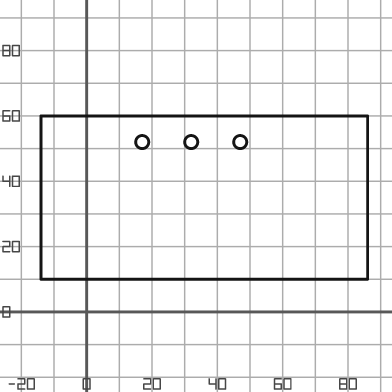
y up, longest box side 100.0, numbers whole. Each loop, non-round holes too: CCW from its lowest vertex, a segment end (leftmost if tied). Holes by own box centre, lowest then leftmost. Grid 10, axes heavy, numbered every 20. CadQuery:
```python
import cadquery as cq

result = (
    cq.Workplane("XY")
    .moveTo(-14.0, 10.0)
    .lineTo(86.0, 10.0)
    .lineTo(86.0, 60.0)
    .lineTo(-14.0, 60.0)
    .close()
    .moveTo(17.0, 52.0)
    .circle(2.0)
    .moveTo(32.0, 52.0)
    .circle(2.0)
    .moveTo(47.0, 52.0)
    .circle(2.0)
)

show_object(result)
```